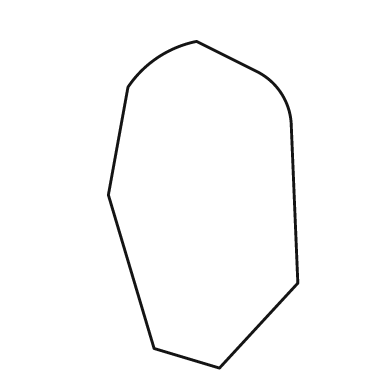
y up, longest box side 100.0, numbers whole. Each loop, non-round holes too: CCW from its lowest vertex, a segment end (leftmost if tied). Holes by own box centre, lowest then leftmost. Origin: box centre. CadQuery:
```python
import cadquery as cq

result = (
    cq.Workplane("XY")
    .moveTo(5.0, -50.0)
    .lineTo(29.0, -24.0)
    .lineTo(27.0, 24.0)
    .threePointArc((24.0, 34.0), (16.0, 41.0))
    .lineTo(-2.0, 50.0)
    .threePointArc((-14.0, 45.0), (-23.0, 36.0))
    .lineTo(-29.0, 3.0)
    .lineTo(-15.0, -44.0)
    .close()
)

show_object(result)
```